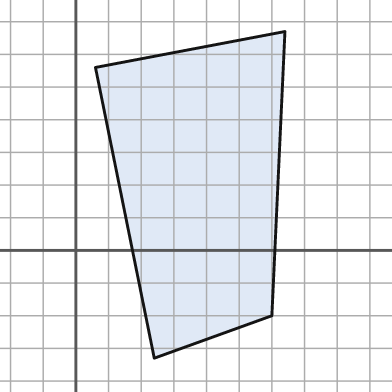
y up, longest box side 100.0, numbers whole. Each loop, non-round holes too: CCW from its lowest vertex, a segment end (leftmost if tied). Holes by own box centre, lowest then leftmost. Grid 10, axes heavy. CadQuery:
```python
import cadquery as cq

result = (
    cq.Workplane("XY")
    .moveTo(24.0, -33.0)
    .lineTo(60.0, -20.0)
    .lineTo(64.0, 67.0)
    .lineTo(6.0, 56.0)
    .close()
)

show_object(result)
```